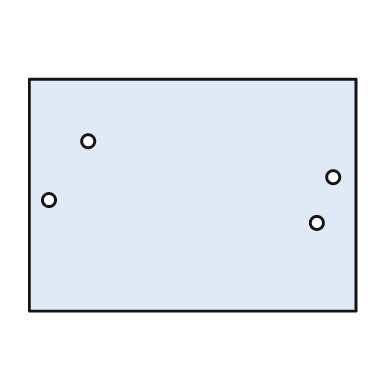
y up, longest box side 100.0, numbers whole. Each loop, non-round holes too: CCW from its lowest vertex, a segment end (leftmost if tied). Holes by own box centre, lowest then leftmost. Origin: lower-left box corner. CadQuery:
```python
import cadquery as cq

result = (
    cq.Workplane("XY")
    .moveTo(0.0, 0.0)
    .lineTo(100.0, 0.0)
    .lineTo(100.0, 71.0)
    .lineTo(0.0, 71.0)
    .close()
    .moveTo(88.0, 27.0)
    .circle(2.0)
    .moveTo(6.0, 34.0)
    .circle(2.0)
    .moveTo(93.0, 41.0)
    .circle(2.0)
    .moveTo(18.0, 52.0)
    .circle(2.0)
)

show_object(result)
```